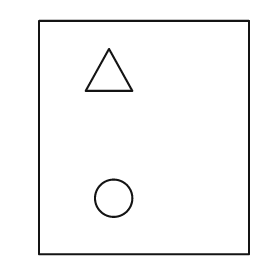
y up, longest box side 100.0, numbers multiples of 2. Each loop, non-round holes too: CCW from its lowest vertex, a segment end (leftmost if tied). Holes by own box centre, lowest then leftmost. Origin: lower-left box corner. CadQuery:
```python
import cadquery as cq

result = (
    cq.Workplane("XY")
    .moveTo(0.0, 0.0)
    .lineTo(90.0, 0.0)
    .lineTo(90.0, 100.0)
    .lineTo(0.0, 100.0)
    .close()
    .moveTo(32.0, 24.0)
    .circle(8.0)
    .moveTo(20.0, 70.0)
    .lineTo(40.0, 70.0)
    .lineTo(30.0, 88.0)
    .close()
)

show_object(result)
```